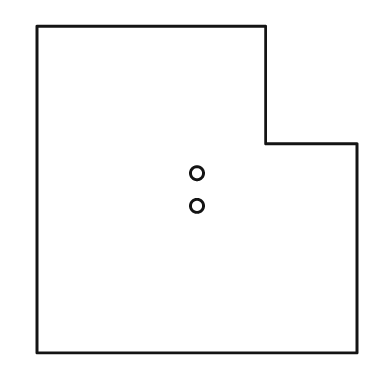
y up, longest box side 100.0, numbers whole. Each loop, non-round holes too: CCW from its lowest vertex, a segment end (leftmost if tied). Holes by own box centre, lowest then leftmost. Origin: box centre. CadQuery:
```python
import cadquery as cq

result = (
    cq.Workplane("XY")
    .moveTo(-49.0, -50.0)
    .lineTo(49.0, -50.0)
    .lineTo(49.0, 14.0)
    .lineTo(21.0, 14.0)
    .lineTo(21.0, 50.0)
    .lineTo(-49.0, 50.0)
    .close()
    .moveTo(0.0, -5.0)
    .circle(2.0)
    .moveTo(0.0, 5.0)
    .circle(2.0)
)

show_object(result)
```